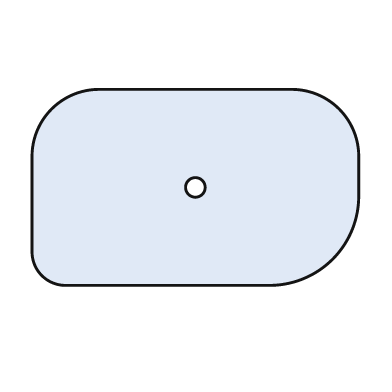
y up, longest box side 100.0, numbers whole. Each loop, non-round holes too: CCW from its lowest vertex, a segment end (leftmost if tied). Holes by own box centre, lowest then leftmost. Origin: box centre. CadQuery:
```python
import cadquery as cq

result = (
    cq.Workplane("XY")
    .moveTo(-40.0, -30.0)
    .lineTo(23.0, -30.0)
    .threePointArc((42.0, -22.0), (50.0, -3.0))
    .lineTo(50.0, 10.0)
    .threePointArc((44.0, 24.0), (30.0, 30.0))
    .lineTo(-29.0, 30.0)
    .threePointArc((-44.0, 24.0), (-50.0, 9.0))
    .lineTo(-50.0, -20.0)
    .threePointArc((-47.0, -27.0), (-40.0, -30.0))
    .close()
    .moveTo(0.0, 0.0)
    .circle(3.0)
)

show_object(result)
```